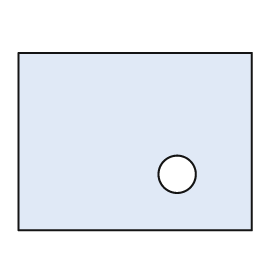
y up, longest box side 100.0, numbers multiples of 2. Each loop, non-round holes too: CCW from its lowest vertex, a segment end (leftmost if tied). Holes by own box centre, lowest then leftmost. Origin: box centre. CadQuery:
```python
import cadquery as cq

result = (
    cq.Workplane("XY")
    .moveTo(-50.0, -38.0)
    .lineTo(50.0, -38.0)
    .lineTo(50.0, 38.0)
    .lineTo(-50.0, 38.0)
    .close()
    .moveTo(18.0, -14.0)
    .circle(8.0)
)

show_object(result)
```